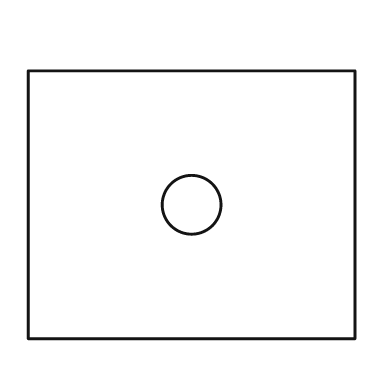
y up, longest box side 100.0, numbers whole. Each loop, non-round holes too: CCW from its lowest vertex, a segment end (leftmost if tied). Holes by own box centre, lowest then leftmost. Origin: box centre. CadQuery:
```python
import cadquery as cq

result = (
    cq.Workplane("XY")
    .moveTo(-50.0, -41.0)
    .lineTo(50.0, -41.0)
    .lineTo(50.0, 41.0)
    .lineTo(-50.0, 41.0)
    .close()
    .moveTo(0.0, 0.0)
    .circle(9.0)
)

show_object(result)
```